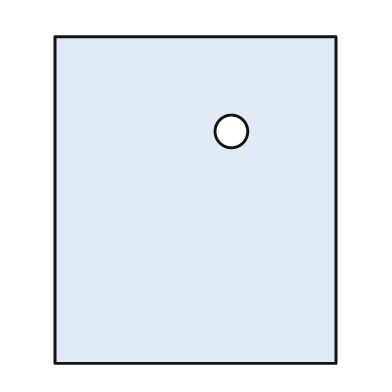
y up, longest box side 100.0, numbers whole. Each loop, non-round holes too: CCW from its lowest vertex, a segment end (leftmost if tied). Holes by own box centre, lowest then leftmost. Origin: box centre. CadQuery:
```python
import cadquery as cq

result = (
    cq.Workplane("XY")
    .moveTo(-43.0, -50.0)
    .lineTo(43.0, -50.0)
    .lineTo(43.0, 50.0)
    .lineTo(-43.0, 50.0)
    .close()
    .moveTo(11.0, 21.0)
    .circle(5.0)
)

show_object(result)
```